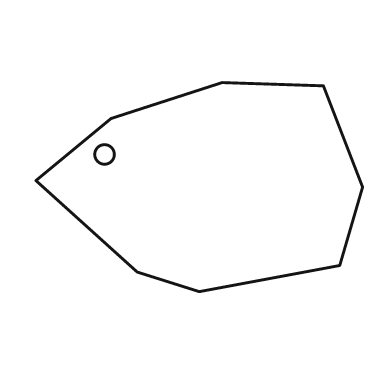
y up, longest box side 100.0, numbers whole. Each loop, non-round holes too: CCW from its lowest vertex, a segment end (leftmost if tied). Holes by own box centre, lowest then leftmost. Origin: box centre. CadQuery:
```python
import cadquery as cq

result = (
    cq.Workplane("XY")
    .moveTo(0.0, -32.0)
    .lineTo(43.0, -24.0)
    .lineTo(50.0, 0.0)
    .lineTo(38.0, 31.0)
    .lineTo(7.0, 32.0)
    .lineTo(-27.0, 21.0)
    .lineTo(-50.0, 2.0)
    .lineTo(-19.0, -26.0)
    .close()
    .moveTo(-29.0, 10.0)
    .circle(3.0)
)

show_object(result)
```